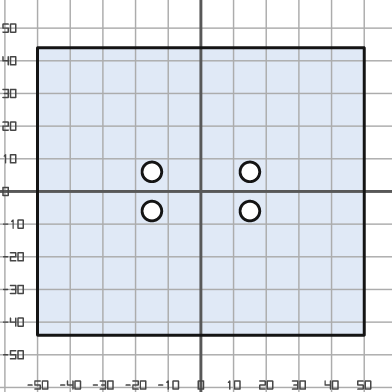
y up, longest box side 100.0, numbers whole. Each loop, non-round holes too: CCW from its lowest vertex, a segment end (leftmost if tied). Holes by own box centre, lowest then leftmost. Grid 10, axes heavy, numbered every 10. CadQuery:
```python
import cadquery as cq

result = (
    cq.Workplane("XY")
    .moveTo(-50.0, -44.0)
    .lineTo(50.0, -44.0)
    .lineTo(50.0, 44.0)
    .lineTo(-50.0, 44.0)
    .close()
    .moveTo(-15.0, -6.0)
    .circle(3.0)
    .moveTo(15.0, -6.0)
    .circle(3.0)
    .moveTo(-15.0, 6.0)
    .circle(3.0)
    .moveTo(15.0, 6.0)
    .circle(3.0)
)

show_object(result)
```